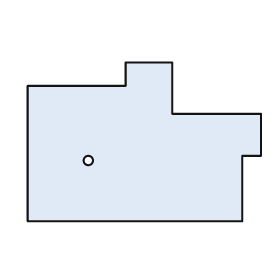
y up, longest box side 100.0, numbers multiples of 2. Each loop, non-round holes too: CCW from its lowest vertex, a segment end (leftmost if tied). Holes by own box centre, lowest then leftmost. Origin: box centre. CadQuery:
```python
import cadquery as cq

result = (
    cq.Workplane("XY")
    .moveTo(-50.0, -34.0)
    .lineTo(42.0, -34.0)
    .lineTo(42.0, -6.0)
    .lineTo(50.0, -6.0)
    .lineTo(50.0, 12.0)
    .lineTo(12.0, 12.0)
    .lineTo(12.0, 34.0)
    .lineTo(-8.0, 34.0)
    .lineTo(-8.0, 24.0)
    .lineTo(-50.0, 24.0)
    .close()
    .moveTo(-24.0, -8.0)
    .circle(2.0)
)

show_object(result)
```